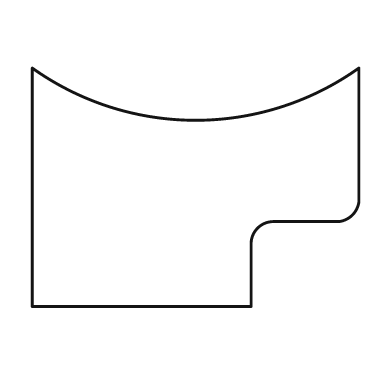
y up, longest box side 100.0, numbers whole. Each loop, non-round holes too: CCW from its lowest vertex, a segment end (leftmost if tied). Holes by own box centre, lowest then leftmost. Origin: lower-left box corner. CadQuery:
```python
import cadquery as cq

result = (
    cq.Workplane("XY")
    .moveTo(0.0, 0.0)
    .lineTo(67.0, 0.0)
    .lineTo(67.0, 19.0)
    .threePointArc((69.0, 24.0), (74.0, 26.0))
    .lineTo(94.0, 26.0)
    .threePointArc((98.0, 28.0), (100.0, 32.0))
    .lineTo(100.0, 73.0)
    .threePointArc((50.0, 57.0), (0.0, 73.0))
    .close()
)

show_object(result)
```